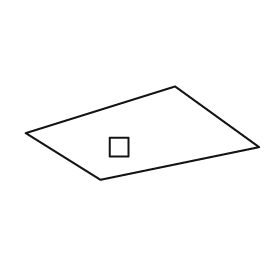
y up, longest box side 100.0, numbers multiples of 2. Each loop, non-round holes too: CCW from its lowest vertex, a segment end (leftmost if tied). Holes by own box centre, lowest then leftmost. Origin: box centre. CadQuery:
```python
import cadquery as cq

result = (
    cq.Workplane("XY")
    .moveTo(-18.0, -20.0)
    .lineTo(50.0, -6.0)
    .lineTo(14.0, 20.0)
    .lineTo(-50.0, 0.0)
    .close()
    .moveTo(-14.0, -10.0)
    .lineTo(-6.0, -10.0)
    .lineTo(-6.0, -2.0)
    .lineTo(-14.0, -2.0)
    .close()
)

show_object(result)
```